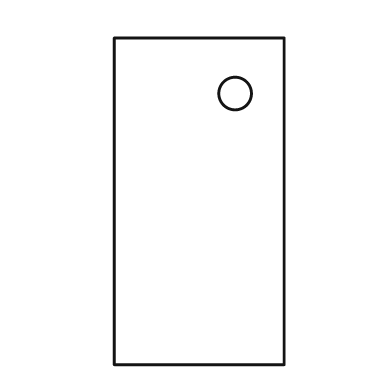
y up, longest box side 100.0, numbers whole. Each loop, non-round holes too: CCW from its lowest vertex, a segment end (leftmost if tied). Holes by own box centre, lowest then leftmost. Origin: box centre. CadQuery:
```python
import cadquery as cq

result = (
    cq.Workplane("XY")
    .moveTo(-26.0, -50.0)
    .lineTo(26.0, -50.0)
    .lineTo(26.0, 50.0)
    .lineTo(-26.0, 50.0)
    .close()
    .moveTo(11.0, 33.0)
    .circle(5.0)
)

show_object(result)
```